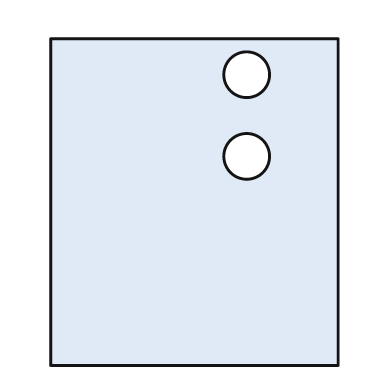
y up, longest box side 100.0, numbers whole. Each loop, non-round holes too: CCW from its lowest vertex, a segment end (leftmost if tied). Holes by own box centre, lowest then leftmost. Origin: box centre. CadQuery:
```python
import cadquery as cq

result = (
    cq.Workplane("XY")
    .moveTo(-44.0, -50.0)
    .lineTo(44.0, -50.0)
    .lineTo(44.0, 50.0)
    .lineTo(-44.0, 50.0)
    .close()
    .moveTo(16.0, 14.0)
    .circle(7.0)
    .moveTo(16.0, 39.0)
    .circle(7.0)
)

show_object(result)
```